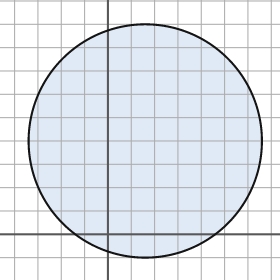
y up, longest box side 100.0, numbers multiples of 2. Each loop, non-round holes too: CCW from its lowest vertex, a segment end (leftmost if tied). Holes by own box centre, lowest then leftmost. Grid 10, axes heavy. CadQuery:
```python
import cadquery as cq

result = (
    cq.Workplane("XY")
    .moveTo(16.0, 40.0)
    .circle(50.0)
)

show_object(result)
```